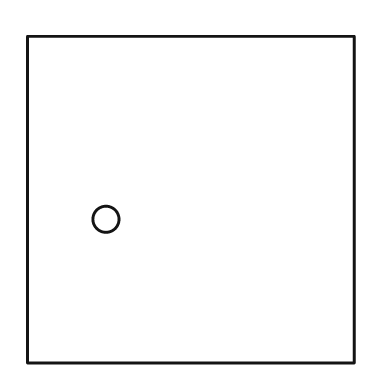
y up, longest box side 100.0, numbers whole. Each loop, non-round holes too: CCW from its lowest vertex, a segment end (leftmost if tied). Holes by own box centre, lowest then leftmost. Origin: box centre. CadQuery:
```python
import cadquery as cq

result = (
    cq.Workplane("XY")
    .moveTo(-50.0, -50.0)
    .lineTo(50.0, -50.0)
    .lineTo(50.0, 50.0)
    .lineTo(-50.0, 50.0)
    .close()
    .moveTo(-26.0, -6.0)
    .circle(4.0)
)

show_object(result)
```